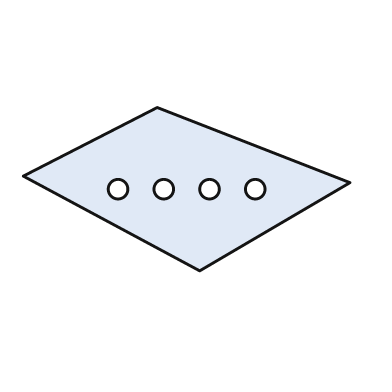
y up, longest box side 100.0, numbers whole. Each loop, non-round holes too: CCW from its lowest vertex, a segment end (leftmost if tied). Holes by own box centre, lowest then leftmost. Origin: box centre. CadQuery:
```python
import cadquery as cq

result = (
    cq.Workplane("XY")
    .moveTo(4.0, -25.0)
    .lineTo(50.0, 2.0)
    .lineTo(-9.0, 25.0)
    .lineTo(-50.0, 4.0)
    .close()
    .moveTo(-21.0, 0.0)
    .circle(3.0)
    .moveTo(-7.0, 0.0)
    .circle(3.0)
    .moveTo(7.0, 0.0)
    .circle(3.0)
    .moveTo(21.0, 0.0)
    .circle(3.0)
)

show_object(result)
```